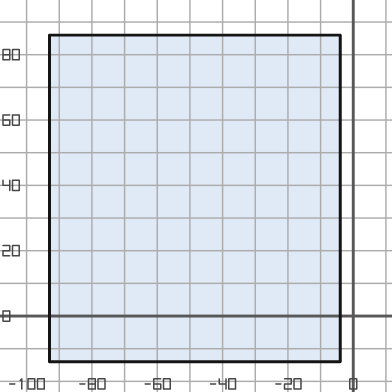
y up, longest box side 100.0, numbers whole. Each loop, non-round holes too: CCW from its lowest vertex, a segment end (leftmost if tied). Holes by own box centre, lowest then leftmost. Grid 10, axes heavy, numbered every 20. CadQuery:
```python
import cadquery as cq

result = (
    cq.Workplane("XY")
    .moveTo(-93.0, -14.0)
    .lineTo(-4.0, -14.0)
    .lineTo(-4.0, 86.0)
    .lineTo(-93.0, 86.0)
    .close()
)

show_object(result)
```